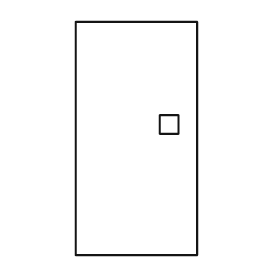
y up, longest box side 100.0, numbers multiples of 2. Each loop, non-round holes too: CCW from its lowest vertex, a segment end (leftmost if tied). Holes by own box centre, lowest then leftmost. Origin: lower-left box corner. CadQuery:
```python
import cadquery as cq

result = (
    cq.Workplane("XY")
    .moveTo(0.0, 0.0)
    .lineTo(52.0, 0.0)
    .lineTo(52.0, 100.0)
    .lineTo(0.0, 100.0)
    .close()
    .moveTo(36.0, 52.0)
    .lineTo(44.0, 52.0)
    .lineTo(44.0, 60.0)
    .lineTo(36.0, 60.0)
    .close()
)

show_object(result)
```